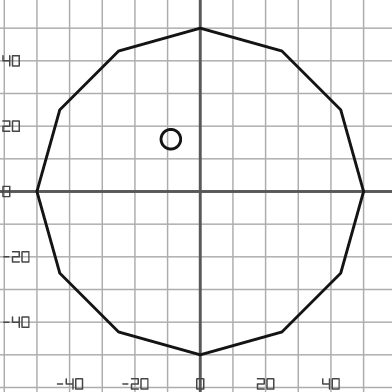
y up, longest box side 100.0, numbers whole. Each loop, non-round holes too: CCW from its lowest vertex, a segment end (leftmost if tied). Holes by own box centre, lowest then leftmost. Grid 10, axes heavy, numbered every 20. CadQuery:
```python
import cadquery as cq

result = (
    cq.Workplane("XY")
    .moveTo(0.0, -50.0)
    .lineTo(25.0, -43.0)
    .lineTo(43.0, -25.0)
    .lineTo(50.0, 0.0)
    .lineTo(43.0, 25.0)
    .lineTo(25.0, 43.0)
    .lineTo(0.0, 50.0)
    .lineTo(-25.0, 43.0)
    .lineTo(-43.0, 25.0)
    .lineTo(-50.0, 0.0)
    .lineTo(-43.0, -25.0)
    .lineTo(-25.0, -43.0)
    .close()
    .moveTo(-9.0, 16.0)
    .circle(3.0)
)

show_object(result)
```